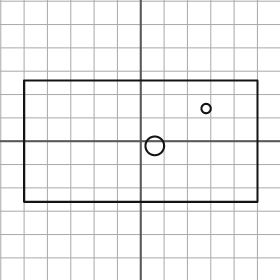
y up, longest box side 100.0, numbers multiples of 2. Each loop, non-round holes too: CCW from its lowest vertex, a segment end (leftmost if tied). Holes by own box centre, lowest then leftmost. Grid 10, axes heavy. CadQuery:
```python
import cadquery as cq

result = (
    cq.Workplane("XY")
    .moveTo(-50.0, -26.0)
    .lineTo(50.0, -26.0)
    .lineTo(50.0, 26.0)
    .lineTo(-50.0, 26.0)
    .close()
    .moveTo(6.0, -2.0)
    .circle(4.0)
    .moveTo(28.0, 14.0)
    .circle(2.0)
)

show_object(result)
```